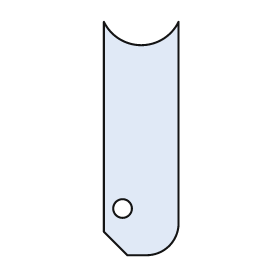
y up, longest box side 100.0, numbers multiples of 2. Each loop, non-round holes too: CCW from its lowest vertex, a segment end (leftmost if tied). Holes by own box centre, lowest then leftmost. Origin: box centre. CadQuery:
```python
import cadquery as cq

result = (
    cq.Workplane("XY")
    .moveTo(-6.0, -50.0)
    .lineTo(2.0, -50.0)
    .threePointArc((12.0, -46.0), (16.0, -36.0))
    .lineTo(16.0, 50.0)
    .threePointArc((0.0, 40.0), (-16.0, 50.0))
    .lineTo(-16.0, -40.0)
    .close()
    .moveTo(-8.0, -30.0)
    .circle(4.0)
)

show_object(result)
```